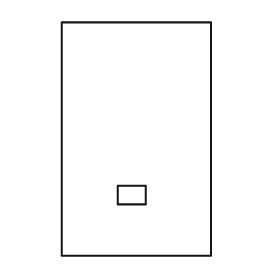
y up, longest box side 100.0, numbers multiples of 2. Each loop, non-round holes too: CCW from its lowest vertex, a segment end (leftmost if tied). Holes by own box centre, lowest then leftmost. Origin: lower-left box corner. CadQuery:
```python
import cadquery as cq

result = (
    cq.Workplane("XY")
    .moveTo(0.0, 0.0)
    .lineTo(64.0, 0.0)
    .lineTo(64.0, 100.0)
    .lineTo(0.0, 100.0)
    .close()
    .moveTo(24.0, 22.0)
    .lineTo(36.0, 22.0)
    .lineTo(36.0, 30.0)
    .lineTo(24.0, 30.0)
    .close()
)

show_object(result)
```